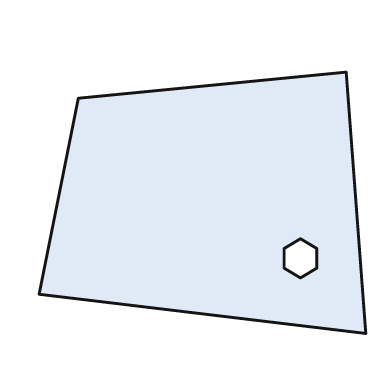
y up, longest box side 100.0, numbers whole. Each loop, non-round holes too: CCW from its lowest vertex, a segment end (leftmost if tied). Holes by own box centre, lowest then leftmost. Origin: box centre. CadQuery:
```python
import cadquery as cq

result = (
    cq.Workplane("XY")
    .moveTo(50.0, -40.0)
    .lineTo(44.0, 40.0)
    .lineTo(-38.0, 32.0)
    .lineTo(-50.0, -28.0)
    .close()
    .moveTo(30.0, -23.0)
    .lineTo(35.0, -20.0)
    .lineTo(35.0, -14.0)
    .lineTo(30.0, -11.0)
    .lineTo(25.0, -14.0)
    .lineTo(25.0, -20.0)
    .close()
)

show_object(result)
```